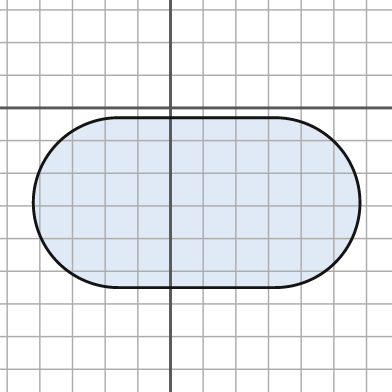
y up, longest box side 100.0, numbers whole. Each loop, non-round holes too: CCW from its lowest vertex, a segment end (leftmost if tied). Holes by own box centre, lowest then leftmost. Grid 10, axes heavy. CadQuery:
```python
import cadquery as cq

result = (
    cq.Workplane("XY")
    .moveTo(-16.0, -55.0)
    .lineTo(32.0, -55.0)
    .threePointArc((58.0, -29.0), (32.0, -3.0))
    .lineTo(-16.0, -3.0)
    .threePointArc((-42.0, -29.0), (-16.0, -55.0))
    .close()
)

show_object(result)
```